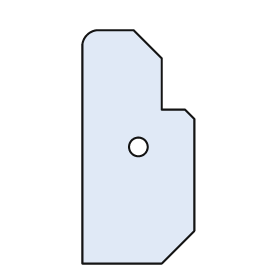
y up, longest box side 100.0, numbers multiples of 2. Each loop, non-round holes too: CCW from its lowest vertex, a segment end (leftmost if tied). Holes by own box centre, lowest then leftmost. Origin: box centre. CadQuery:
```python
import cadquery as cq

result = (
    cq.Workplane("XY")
    .moveTo(-24.0, -50.0)
    .lineTo(10.0, -50.0)
    .lineTo(24.0, -36.0)
    .lineTo(24.0, 12.0)
    .lineTo(20.0, 16.0)
    .lineTo(10.0, 16.0)
    .lineTo(10.0, 38.0)
    .lineTo(-2.0, 50.0)
    .lineTo(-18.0, 50.0)
    .threePointArc((-22.0, 48.0), (-24.0, 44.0))
    .close()
    .moveTo(0.0, 0.0)
    .circle(4.0)
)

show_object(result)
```